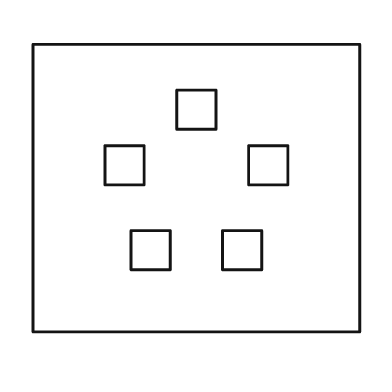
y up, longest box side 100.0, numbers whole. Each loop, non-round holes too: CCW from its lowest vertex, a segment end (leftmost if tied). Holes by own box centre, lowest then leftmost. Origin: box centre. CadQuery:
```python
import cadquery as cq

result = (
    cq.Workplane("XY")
    .moveTo(-50.0, -44.0)
    .lineTo(50.0, -44.0)
    .lineTo(50.0, 44.0)
    .lineTo(-50.0, 44.0)
    .close()
    .moveTo(-20.0, -25.0)
    .lineTo(-8.0, -25.0)
    .lineTo(-8.0, -13.0)
    .lineTo(-20.0, -13.0)
    .close()
    .moveTo(8.0, -25.0)
    .lineTo(20.0, -25.0)
    .lineTo(20.0, -13.0)
    .lineTo(8.0, -13.0)
    .close()
    .moveTo(-28.0, 1.0)
    .lineTo(-16.0, 1.0)
    .lineTo(-16.0, 13.0)
    .lineTo(-28.0, 13.0)
    .close()
    .moveTo(16.0, 1.0)
    .lineTo(28.0, 1.0)
    .lineTo(28.0, 13.0)
    .lineTo(16.0, 13.0)
    .close()
    .moveTo(-6.0, 18.0)
    .lineTo(6.0, 18.0)
    .lineTo(6.0, 30.0)
    .lineTo(-6.0, 30.0)
    .close()
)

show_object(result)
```